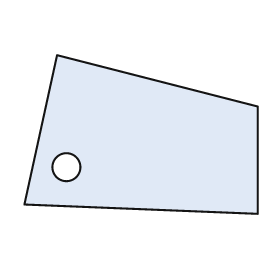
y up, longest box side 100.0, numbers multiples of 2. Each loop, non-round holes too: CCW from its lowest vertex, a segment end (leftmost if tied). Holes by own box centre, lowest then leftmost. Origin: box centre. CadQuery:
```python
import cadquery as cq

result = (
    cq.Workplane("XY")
    .moveTo(50.0, -34.0)
    .lineTo(50.0, 12.0)
    .lineTo(-36.0, 34.0)
    .lineTo(-50.0, -30.0)
    .close()
    .moveTo(-32.0, -14.0)
    .circle(6.0)
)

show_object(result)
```